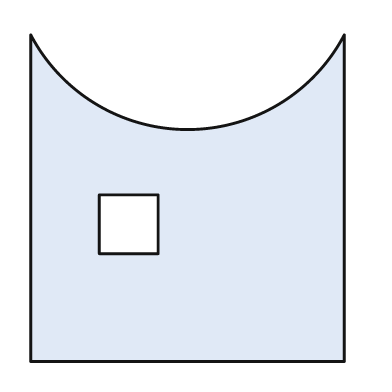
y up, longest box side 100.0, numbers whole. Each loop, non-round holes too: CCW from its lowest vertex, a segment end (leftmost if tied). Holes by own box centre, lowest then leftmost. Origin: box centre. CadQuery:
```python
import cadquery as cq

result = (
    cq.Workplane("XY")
    .moveTo(-48.0, -50.0)
    .lineTo(48.0, -50.0)
    .lineTo(48.0, 50.0)
    .threePointArc((0.0, 21.0), (-48.0, 50.0))
    .close()
    .moveTo(-27.0, -17.0)
    .lineTo(-9.0, -17.0)
    .lineTo(-9.0, 1.0)
    .lineTo(-27.0, 1.0)
    .close()
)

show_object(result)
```